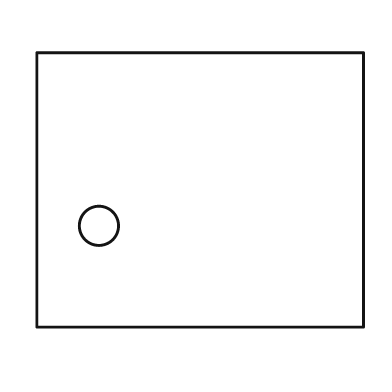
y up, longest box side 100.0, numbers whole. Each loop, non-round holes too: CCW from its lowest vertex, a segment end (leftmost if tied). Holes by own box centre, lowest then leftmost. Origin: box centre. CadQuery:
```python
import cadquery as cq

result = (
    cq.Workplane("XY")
    .moveTo(-50.0, -42.0)
    .lineTo(50.0, -42.0)
    .lineTo(50.0, 42.0)
    .lineTo(-50.0, 42.0)
    .close()
    .moveTo(-31.0, -11.0)
    .circle(6.0)
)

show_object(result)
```